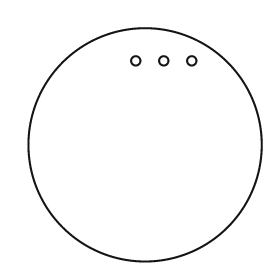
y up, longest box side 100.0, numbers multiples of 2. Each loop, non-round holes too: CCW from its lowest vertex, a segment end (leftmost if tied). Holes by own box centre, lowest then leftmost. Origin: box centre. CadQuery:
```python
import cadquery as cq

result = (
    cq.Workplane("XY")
    .moveTo(0.0, 0.0)
    .circle(50.0)
    .moveTo(-4.0, 36.0)
    .circle(2.0)
    .moveTo(8.0, 36.0)
    .circle(2.0)
    .moveTo(20.0, 36.0)
    .circle(2.0)
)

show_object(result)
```